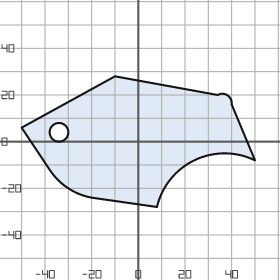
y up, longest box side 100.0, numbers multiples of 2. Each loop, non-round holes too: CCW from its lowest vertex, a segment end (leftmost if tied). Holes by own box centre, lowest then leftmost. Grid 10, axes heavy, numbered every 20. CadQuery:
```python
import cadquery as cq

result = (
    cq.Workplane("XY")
    .moveTo(8.0, -28.0)
    .threePointArc((24.0, -8.0), (50.0, -8.0))
    .lineTo(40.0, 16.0)
    .threePointArc((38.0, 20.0), (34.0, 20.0))
    .lineTo(-10.0, 28.0)
    .lineTo(-50.0, 6.0)
    .lineTo(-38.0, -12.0)
    .threePointArc((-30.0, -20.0), (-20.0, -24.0))
    .close()
    .moveTo(-34.0, 4.0)
    .circle(4.0)
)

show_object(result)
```